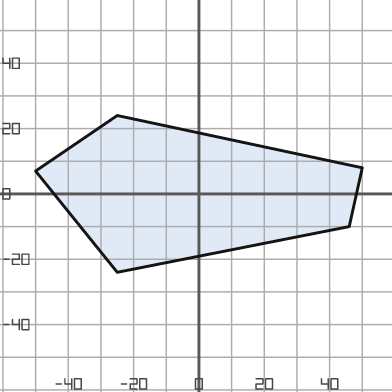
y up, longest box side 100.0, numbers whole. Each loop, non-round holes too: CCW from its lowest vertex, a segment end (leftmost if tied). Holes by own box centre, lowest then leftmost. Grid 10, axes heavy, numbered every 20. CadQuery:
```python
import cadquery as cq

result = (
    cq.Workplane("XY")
    .moveTo(-25.0, -24.0)
    .lineTo(46.0, -10.0)
    .lineTo(50.0, 8.0)
    .lineTo(-25.0, 24.0)
    .lineTo(-50.0, 7.0)
    .close()
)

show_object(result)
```